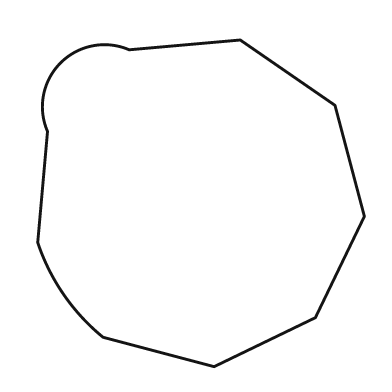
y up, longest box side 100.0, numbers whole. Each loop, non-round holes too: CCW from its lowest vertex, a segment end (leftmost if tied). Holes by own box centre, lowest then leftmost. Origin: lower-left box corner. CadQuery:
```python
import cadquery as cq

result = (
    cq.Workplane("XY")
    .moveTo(54.0, 0.0)
    .lineTo(85.0, 15.0)
    .lineTo(100.0, 46.0)
    .lineTo(91.0, 80.0)
    .lineTo(62.0, 100.0)
    .lineTo(28.0, 97.0)
    .threePointArc((7.0, 93.0), (3.0, 72.0))
    .lineTo(0.0, 38.0)
    .threePointArc((8.0, 22.0), (20.0, 9.0))
    .close()
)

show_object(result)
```